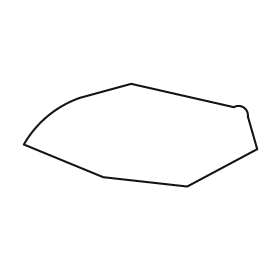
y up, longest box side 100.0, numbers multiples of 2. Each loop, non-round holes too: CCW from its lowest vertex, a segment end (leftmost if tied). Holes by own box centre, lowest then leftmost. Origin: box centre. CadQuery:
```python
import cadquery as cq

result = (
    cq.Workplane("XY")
    .moveTo(20.0, -22.0)
    .lineTo(50.0, -6.0)
    .lineTo(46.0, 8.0)
    .threePointArc((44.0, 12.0), (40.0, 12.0))
    .lineTo(-4.0, 22.0)
    .lineTo(-26.0, 16.0)
    .threePointArc((-40.0, 8.0), (-50.0, -4.0))
    .lineTo(-16.0, -18.0)
    .close()
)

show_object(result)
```